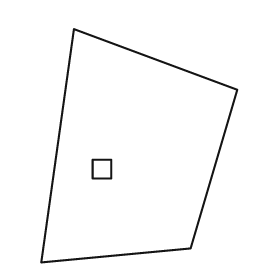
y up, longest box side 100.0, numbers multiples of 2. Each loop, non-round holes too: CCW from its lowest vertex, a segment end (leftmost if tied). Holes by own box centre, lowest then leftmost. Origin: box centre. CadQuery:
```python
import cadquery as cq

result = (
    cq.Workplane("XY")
    .moveTo(-42.0, -50.0)
    .lineTo(22.0, -44.0)
    .lineTo(42.0, 24.0)
    .lineTo(-28.0, 50.0)
    .close()
    .moveTo(-20.0, -14.0)
    .lineTo(-12.0, -14.0)
    .lineTo(-12.0, -6.0)
    .lineTo(-20.0, -6.0)
    .close()
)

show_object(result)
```